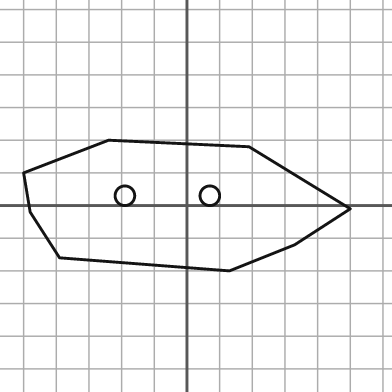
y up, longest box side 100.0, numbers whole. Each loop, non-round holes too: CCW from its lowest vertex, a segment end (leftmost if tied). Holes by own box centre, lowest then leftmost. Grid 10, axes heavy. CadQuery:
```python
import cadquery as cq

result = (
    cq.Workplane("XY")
    .moveTo(13.0, -20.0)
    .lineTo(33.0, -12.0)
    .lineTo(50.0, -1.0)
    .lineTo(19.0, 18.0)
    .lineTo(-24.0, 20.0)
    .lineTo(-50.0, 10.0)
    .lineTo(-48.0, -2.0)
    .lineTo(-39.0, -16.0)
    .close()
    .moveTo(-19.0, 3.0)
    .circle(3.0)
    .moveTo(7.0, 3.0)
    .circle(3.0)
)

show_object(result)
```